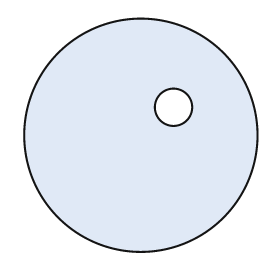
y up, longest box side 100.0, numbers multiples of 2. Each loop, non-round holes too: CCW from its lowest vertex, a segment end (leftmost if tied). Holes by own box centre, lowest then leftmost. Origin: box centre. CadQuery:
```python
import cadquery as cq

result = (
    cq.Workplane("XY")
    .moveTo(0.0, 0.0)
    .circle(50.0)
    .moveTo(14.0, 12.0)
    .circle(8.0)
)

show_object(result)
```